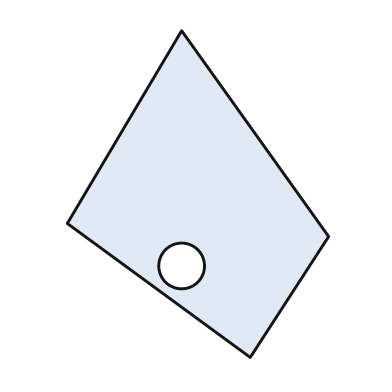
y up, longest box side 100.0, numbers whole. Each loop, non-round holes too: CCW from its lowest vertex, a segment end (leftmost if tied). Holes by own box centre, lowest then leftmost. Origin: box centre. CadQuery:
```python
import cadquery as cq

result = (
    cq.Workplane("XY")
    .moveTo(16.0, -50.0)
    .lineTo(40.0, -13.0)
    .lineTo(-5.0, 50.0)
    .lineTo(-40.0, -9.0)
    .close()
    .moveTo(-5.0, -22.0)
    .circle(7.0)
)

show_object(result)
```